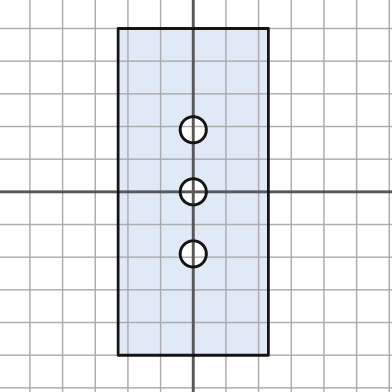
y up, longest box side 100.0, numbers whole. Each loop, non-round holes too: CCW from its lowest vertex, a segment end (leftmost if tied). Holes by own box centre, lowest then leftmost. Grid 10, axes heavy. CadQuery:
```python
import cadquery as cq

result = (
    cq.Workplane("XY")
    .moveTo(-23.0, -50.0)
    .lineTo(23.0, -50.0)
    .lineTo(23.0, 50.0)
    .lineTo(-23.0, 50.0)
    .close()
    .moveTo(0.0, -19.0)
    .circle(4.0)
    .moveTo(0.0, 0.0)
    .circle(4.0)
    .moveTo(0.0, 19.0)
    .circle(4.0)
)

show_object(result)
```